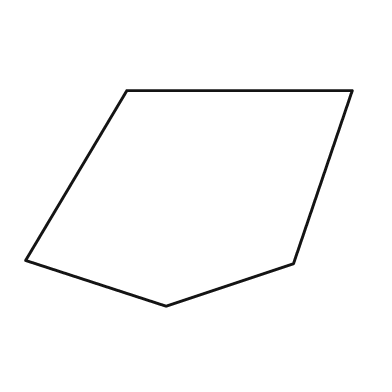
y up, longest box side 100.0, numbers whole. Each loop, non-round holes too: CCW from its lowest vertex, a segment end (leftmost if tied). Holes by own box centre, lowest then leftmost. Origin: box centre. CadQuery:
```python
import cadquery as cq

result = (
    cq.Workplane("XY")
    .moveTo(-7.0, -33.0)
    .lineTo(32.0, -20.0)
    .lineTo(50.0, 33.0)
    .lineTo(-19.0, 33.0)
    .lineTo(-50.0, -19.0)
    .close()
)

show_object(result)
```